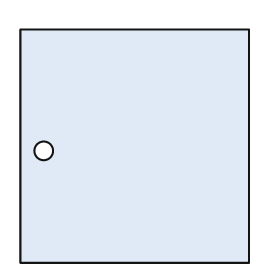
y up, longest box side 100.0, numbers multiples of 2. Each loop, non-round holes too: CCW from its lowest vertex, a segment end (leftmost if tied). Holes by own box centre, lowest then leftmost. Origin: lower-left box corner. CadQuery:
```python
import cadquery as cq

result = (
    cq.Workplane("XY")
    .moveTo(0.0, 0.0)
    .lineTo(98.0, 0.0)
    .lineTo(98.0, 100.0)
    .lineTo(0.0, 100.0)
    .close()
    .moveTo(10.0, 48.0)
    .circle(4.0)
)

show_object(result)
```